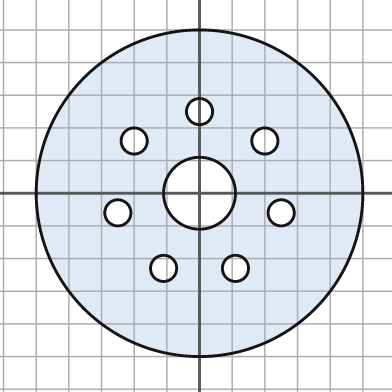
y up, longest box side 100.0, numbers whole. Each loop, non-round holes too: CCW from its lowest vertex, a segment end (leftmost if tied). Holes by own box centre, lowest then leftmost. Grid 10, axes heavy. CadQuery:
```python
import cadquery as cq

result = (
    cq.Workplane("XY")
    .moveTo(0.0, 0.0)
    .circle(50.0)
    .moveTo(-11.0, -23.0)
    .circle(4.0)
    .moveTo(11.0, -23.0)
    .circle(4.0)
    .moveTo(-25.0, -6.0)
    .circle(4.0)
    .moveTo(25.0, -6.0)
    .circle(4.0)
    .moveTo(0.0, 0.0)
    .circle(11.0)
    .moveTo(-20.0, 16.0)
    .circle(4.0)
    .moveTo(20.0, 16.0)
    .circle(4.0)
    .moveTo(0.0, 25.0)
    .circle(4.0)
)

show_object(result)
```